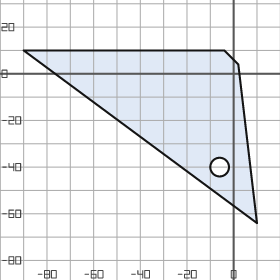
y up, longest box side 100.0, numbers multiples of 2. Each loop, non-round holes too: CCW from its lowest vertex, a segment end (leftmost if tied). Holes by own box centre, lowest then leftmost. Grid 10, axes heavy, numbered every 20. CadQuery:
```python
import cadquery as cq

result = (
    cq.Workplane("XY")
    .moveTo(10.0, -64.0)
    .lineTo(2.0, 4.0)
    .lineTo(-4.0, 10.0)
    .lineTo(-90.0, 10.0)
    .close()
    .moveTo(-6.0, -40.0)
    .circle(4.0)
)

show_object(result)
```